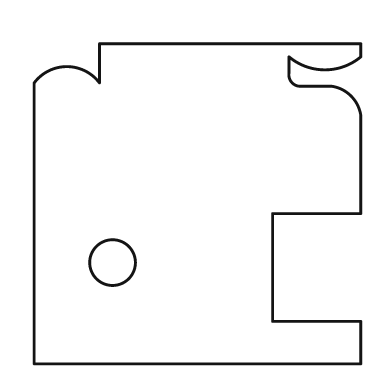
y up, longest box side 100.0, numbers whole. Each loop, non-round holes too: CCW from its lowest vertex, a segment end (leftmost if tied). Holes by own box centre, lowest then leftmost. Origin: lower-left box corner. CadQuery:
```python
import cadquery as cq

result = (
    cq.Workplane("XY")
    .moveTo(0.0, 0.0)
    .lineTo(100.0, 0.0)
    .lineTo(100.0, 13.0)
    .lineTo(73.0, 13.0)
    .lineTo(73.0, 46.0)
    .lineTo(100.0, 46.0)
    .lineTo(100.0, 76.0)
    .threePointArc((97.0, 82.0), (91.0, 85.0))
    .lineTo(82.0, 85.0)
    .threePointArc((79.0, 86.0), (78.0, 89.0))
    .lineTo(78.0, 94.0)
    .threePointArc((89.0, 90.0), (100.0, 94.0))
    .lineTo(100.0, 98.0)
    .lineTo(20.0, 98.0)
    .lineTo(20.0, 86.0)
    .threePointArc((10.0, 91.0), (0.0, 86.0))
    .close()
    .moveTo(24.0, 31.0)
    .circle(7.0)
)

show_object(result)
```